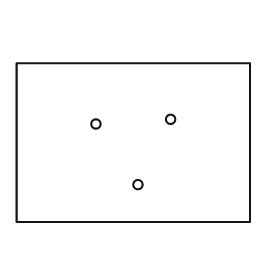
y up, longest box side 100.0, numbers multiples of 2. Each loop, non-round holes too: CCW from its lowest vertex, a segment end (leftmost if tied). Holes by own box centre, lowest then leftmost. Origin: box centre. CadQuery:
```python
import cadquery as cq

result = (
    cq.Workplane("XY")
    .moveTo(-50.0, -34.0)
    .lineTo(50.0, -34.0)
    .lineTo(50.0, 34.0)
    .lineTo(-50.0, 34.0)
    .close()
    .moveTo(2.0, -18.0)
    .circle(2.0)
    .moveTo(-16.0, 8.0)
    .circle(2.0)
    .moveTo(16.0, 10.0)
    .circle(2.0)
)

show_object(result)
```